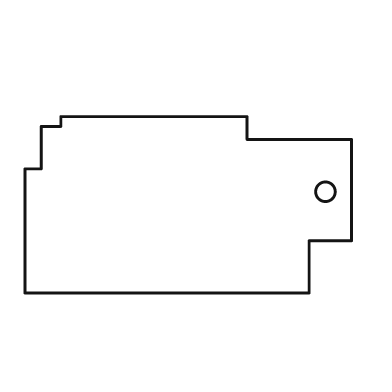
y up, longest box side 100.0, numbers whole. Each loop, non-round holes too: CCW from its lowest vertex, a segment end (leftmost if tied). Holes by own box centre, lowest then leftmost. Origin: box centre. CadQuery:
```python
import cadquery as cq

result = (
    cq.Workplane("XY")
    .moveTo(-50.0, -27.0)
    .lineTo(37.0, -27.0)
    .lineTo(37.0, -11.0)
    .lineTo(50.0, -11.0)
    .lineTo(50.0, 20.0)
    .lineTo(18.0, 20.0)
    .lineTo(18.0, 27.0)
    .lineTo(-39.0, 27.0)
    .lineTo(-39.0, 24.0)
    .lineTo(-45.0, 24.0)
    .lineTo(-45.0, 11.0)
    .lineTo(-50.0, 11.0)
    .close()
    .moveTo(42.0, 4.0)
    .circle(3.0)
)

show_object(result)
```